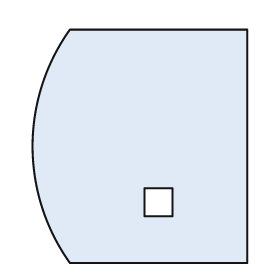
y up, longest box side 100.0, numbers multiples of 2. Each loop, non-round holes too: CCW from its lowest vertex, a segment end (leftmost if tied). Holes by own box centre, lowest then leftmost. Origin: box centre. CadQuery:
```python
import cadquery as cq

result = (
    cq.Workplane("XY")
    .moveTo(-30.0, -50.0)
    .lineTo(46.0, -50.0)
    .lineTo(46.0, 50.0)
    .lineTo(-30.0, 50.0)
    .threePointArc((-46.0, 0.0), (-30.0, -50.0))
    .close()
    .moveTo(2.0, -30.0)
    .lineTo(14.0, -30.0)
    .lineTo(14.0, -18.0)
    .lineTo(2.0, -18.0)
    .close()
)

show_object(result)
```